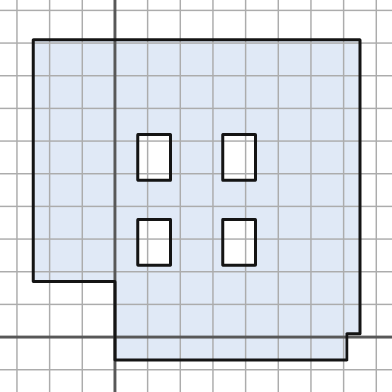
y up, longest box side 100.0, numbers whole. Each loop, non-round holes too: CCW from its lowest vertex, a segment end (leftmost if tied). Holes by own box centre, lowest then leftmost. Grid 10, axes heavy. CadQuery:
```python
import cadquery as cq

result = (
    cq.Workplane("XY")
    .moveTo(0.0, -7.0)
    .lineTo(71.0, -7.0)
    .lineTo(71.0, 1.0)
    .lineTo(75.0, 1.0)
    .lineTo(75.0, 91.0)
    .lineTo(-25.0, 91.0)
    .lineTo(-25.0, 17.0)
    .lineTo(0.0, 17.0)
    .close()
    .moveTo(7.0, 22.0)
    .lineTo(17.0, 22.0)
    .lineTo(17.0, 36.0)
    .lineTo(7.0, 36.0)
    .close()
    .moveTo(33.0, 22.0)
    .lineTo(43.0, 22.0)
    .lineTo(43.0, 36.0)
    .lineTo(33.0, 36.0)
    .close()
    .moveTo(7.0, 48.0)
    .lineTo(17.0, 48.0)
    .lineTo(17.0, 62.0)
    .lineTo(7.0, 62.0)
    .close()
    .moveTo(33.0, 48.0)
    .lineTo(43.0, 48.0)
    .lineTo(43.0, 62.0)
    .lineTo(33.0, 62.0)
    .close()
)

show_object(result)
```